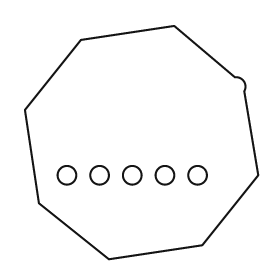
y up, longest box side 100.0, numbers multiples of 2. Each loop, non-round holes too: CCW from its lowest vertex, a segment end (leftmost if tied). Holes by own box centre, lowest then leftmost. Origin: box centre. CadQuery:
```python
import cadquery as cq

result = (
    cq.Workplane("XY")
    .moveTo(-14.0, -50.0)
    .lineTo(26.0, -44.0)
    .lineTo(50.0, -14.0)
    .lineTo(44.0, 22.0)
    .threePointArc((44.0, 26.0), (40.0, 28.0))
    .lineTo(14.0, 50.0)
    .lineTo(-26.0, 44.0)
    .lineTo(-50.0, 14.0)
    .lineTo(-44.0, -26.0)
    .close()
    .moveTo(-32.0, -14.0)
    .circle(4.0)
    .moveTo(-18.0, -14.0)
    .circle(4.0)
    .moveTo(-4.0, -14.0)
    .circle(4.0)
    .moveTo(10.0, -14.0)
    .circle(4.0)
    .moveTo(24.0, -14.0)
    .circle(4.0)
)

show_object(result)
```